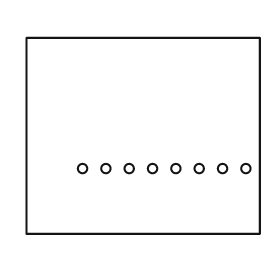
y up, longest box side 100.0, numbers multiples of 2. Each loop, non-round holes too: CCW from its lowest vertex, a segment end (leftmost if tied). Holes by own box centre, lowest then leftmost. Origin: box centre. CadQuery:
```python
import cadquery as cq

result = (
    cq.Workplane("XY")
    .moveTo(-50.0, -42.0)
    .lineTo(50.0, -42.0)
    .lineTo(50.0, 42.0)
    .lineTo(-50.0, 42.0)
    .close()
    .moveTo(-26.0, -14.0)
    .circle(2.0)
    .moveTo(-16.0, -14.0)
    .circle(2.0)
    .moveTo(-6.0, -14.0)
    .circle(2.0)
    .moveTo(4.0, -14.0)
    .circle(2.0)
    .moveTo(14.0, -14.0)
    .circle(2.0)
    .moveTo(24.0, -14.0)
    .circle(2.0)
    .moveTo(34.0, -14.0)
    .circle(2.0)
    .moveTo(44.0, -14.0)
    .circle(2.0)
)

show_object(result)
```